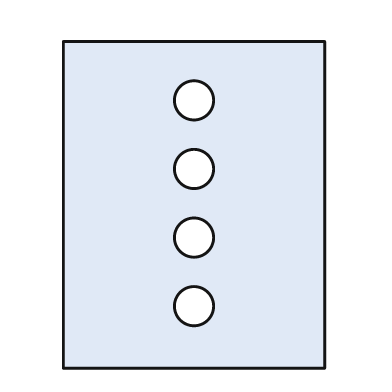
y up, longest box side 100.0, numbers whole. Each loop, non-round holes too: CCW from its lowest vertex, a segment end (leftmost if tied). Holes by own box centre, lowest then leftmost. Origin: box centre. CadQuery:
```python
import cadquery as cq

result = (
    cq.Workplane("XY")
    .moveTo(-40.0, -50.0)
    .lineTo(40.0, -50.0)
    .lineTo(40.0, 50.0)
    .lineTo(-40.0, 50.0)
    .close()
    .moveTo(0.0, -31.0)
    .circle(6.0)
    .moveTo(0.0, -10.0)
    .circle(6.0)
    .moveTo(0.0, 11.0)
    .circle(6.0)
    .moveTo(0.0, 32.0)
    .circle(6.0)
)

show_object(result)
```